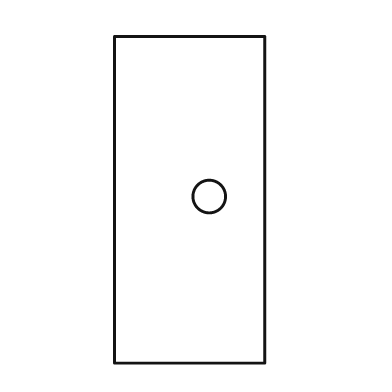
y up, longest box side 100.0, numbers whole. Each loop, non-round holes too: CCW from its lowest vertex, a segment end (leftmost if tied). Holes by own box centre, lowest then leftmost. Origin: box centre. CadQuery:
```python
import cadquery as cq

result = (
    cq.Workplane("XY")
    .moveTo(-23.0, -50.0)
    .lineTo(23.0, -50.0)
    .lineTo(23.0, 50.0)
    .lineTo(-23.0, 50.0)
    .close()
    .moveTo(6.0, 1.0)
    .circle(5.0)
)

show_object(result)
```